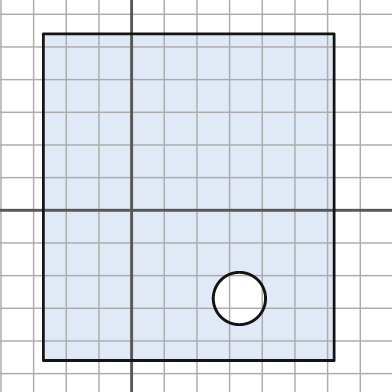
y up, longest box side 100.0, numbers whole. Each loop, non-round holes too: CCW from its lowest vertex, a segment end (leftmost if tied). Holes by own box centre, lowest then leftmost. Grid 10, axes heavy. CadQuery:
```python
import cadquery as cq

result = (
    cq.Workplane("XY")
    .moveTo(-27.0, -46.0)
    .lineTo(62.0, -46.0)
    .lineTo(62.0, 54.0)
    .lineTo(-27.0, 54.0)
    .close()
    .moveTo(33.0, -27.0)
    .circle(8.0)
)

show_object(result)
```